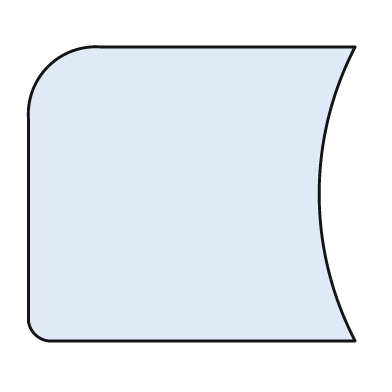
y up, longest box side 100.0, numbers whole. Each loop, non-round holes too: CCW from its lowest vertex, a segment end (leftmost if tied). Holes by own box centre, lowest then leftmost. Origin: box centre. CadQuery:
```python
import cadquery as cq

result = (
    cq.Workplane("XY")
    .moveTo(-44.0, -45.0)
    .lineTo(50.0, -45.0)
    .threePointArc((39.0, 0.0), (50.0, 45.0))
    .lineTo(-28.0, 45.0)
    .threePointArc((-44.0, 39.0), (-50.0, 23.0))
    .lineTo(-50.0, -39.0)
    .threePointArc((-48.0, -43.0), (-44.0, -45.0))
    .close()
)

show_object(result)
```